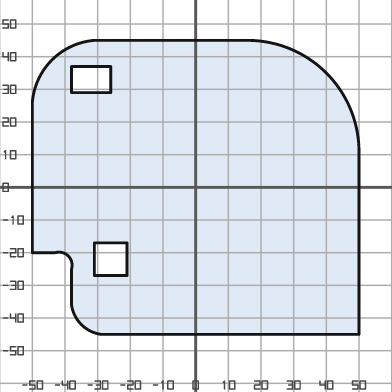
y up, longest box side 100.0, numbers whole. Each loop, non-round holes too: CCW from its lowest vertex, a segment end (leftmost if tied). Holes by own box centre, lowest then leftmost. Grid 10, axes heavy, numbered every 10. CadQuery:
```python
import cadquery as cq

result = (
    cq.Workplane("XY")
    .moveTo(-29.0, -45.0)
    .lineTo(50.0, -45.0)
    .lineTo(50.0, 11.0)
    .threePointArc((40.0, 35.0), (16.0, 45.0))
    .lineTo(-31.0, 45.0)
    .threePointArc((-44.0, 39.0), (-50.0, 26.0))
    .lineTo(-50.0, -20.0)
    .lineTo(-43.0, -20.0)
    .threePointArc((-39.0, -21.0), (-38.0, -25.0))
    .lineTo(-38.0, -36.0)
    .threePointArc((-35.0, -42.0), (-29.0, -45.0))
    .close()
    .moveTo(-31.0, -27.0)
    .lineTo(-21.0, -27.0)
    .lineTo(-21.0, -17.0)
    .lineTo(-31.0, -17.0)
    .close()
    .moveTo(-38.0, 29.0)
    .lineTo(-26.0, 29.0)
    .lineTo(-26.0, 37.0)
    .lineTo(-38.0, 37.0)
    .close()
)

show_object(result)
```